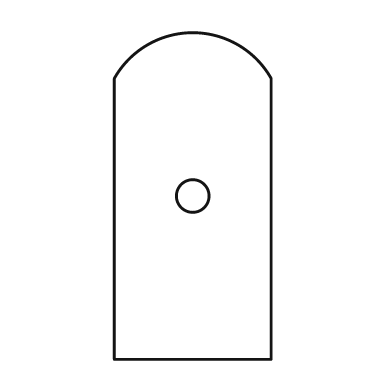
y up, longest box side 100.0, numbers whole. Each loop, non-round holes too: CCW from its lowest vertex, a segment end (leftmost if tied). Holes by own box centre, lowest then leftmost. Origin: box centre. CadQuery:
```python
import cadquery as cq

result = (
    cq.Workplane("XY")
    .moveTo(-24.0, -50.0)
    .lineTo(24.0, -50.0)
    .lineTo(24.0, 36.0)
    .threePointArc((0.0, 50.0), (-24.0, 36.0))
    .close()
    .moveTo(0.0, 0.0)
    .circle(5.0)
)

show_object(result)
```